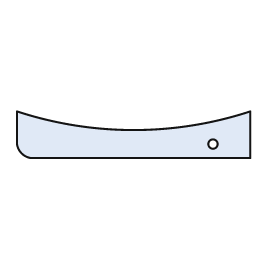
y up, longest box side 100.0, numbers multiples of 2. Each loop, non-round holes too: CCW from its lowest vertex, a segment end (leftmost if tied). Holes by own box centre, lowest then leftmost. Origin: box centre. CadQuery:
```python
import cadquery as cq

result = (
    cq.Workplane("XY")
    .moveTo(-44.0, -10.0)
    .lineTo(50.0, -10.0)
    .lineTo(50.0, 10.0)
    .threePointArc((0.0, 2.0), (-50.0, 10.0))
    .lineTo(-50.0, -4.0)
    .threePointArc((-48.0, -8.0), (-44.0, -10.0))
    .close()
    .moveTo(34.0, -4.0)
    .circle(2.0)
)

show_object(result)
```